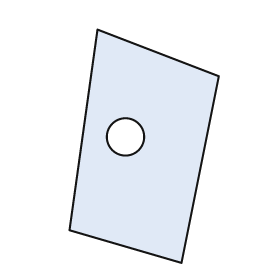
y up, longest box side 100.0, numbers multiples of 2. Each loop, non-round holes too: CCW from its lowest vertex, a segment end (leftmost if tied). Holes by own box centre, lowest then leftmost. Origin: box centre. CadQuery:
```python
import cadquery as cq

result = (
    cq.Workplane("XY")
    .moveTo(16.0, -50.0)
    .lineTo(32.0, 30.0)
    .lineTo(-20.0, 50.0)
    .lineTo(-32.0, -36.0)
    .close()
    .moveTo(-8.0, 4.0)
    .circle(8.0)
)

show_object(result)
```